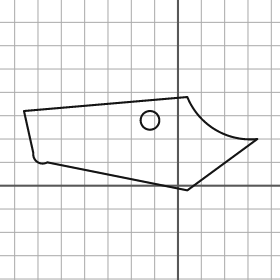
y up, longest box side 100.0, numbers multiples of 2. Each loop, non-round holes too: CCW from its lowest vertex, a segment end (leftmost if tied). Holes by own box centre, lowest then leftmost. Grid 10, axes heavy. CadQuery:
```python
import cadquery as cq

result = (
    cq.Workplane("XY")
    .moveTo(4.0, -2.0)
    .lineTo(34.0, 20.0)
    .threePointArc((16.0, 24.0), (4.0, 38.0))
    .lineTo(-66.0, 32.0)
    .lineTo(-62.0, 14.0)
    .threePointArc((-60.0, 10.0), (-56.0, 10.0))
    .close()
    .moveTo(-12.0, 28.0)
    .circle(4.0)
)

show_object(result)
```